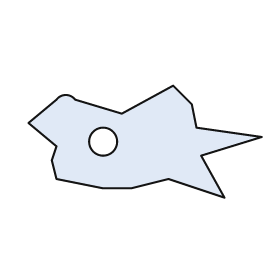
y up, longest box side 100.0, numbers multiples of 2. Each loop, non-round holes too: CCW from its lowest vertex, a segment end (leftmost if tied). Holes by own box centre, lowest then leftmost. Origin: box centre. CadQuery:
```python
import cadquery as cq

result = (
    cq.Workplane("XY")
    .moveTo(34.0, -24.0)
    .lineTo(24.0, -6.0)
    .lineTo(50.0, 2.0)
    .lineTo(22.0, 6.0)
    .lineTo(20.0, 16.0)
    .lineTo(12.0, 24.0)
    .lineTo(-10.0, 12.0)
    .lineTo(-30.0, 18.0)
    .threePointArc((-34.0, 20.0), (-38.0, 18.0))
    .lineTo(-50.0, 8.0)
    .lineTo(-38.0, -2.0)
    .lineTo(-40.0, -8.0)
    .lineTo(-38.0, -16.0)
    .lineTo(-18.0, -20.0)
    .lineTo(-6.0, -20.0)
    .lineTo(10.0, -16.0)
    .close()
    .moveTo(-18.0, 0.0)
    .circle(6.0)
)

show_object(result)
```